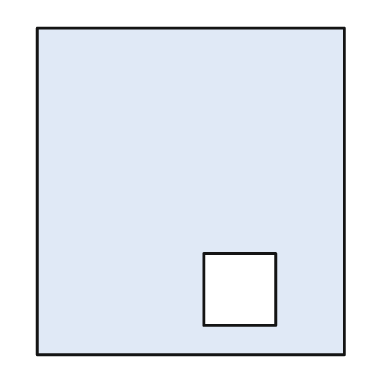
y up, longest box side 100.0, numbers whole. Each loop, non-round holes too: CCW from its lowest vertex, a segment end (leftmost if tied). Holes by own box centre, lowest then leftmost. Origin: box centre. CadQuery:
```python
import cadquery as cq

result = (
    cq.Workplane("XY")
    .moveTo(-47.0, -50.0)
    .lineTo(47.0, -50.0)
    .lineTo(47.0, 50.0)
    .lineTo(-47.0, 50.0)
    .close()
    .moveTo(4.0, -41.0)
    .lineTo(26.0, -41.0)
    .lineTo(26.0, -19.0)
    .lineTo(4.0, -19.0)
    .close()
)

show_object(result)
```